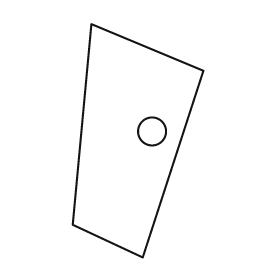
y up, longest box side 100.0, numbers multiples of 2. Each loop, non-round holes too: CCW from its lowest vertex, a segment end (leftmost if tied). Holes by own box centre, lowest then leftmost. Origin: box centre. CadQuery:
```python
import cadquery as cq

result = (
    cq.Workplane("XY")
    .moveTo(2.0, -50.0)
    .lineTo(28.0, 30.0)
    .lineTo(-20.0, 50.0)
    .lineTo(-28.0, -36.0)
    .close()
    .moveTo(6.0, 4.0)
    .circle(6.0)
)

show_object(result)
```